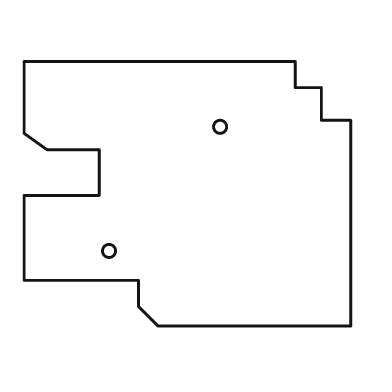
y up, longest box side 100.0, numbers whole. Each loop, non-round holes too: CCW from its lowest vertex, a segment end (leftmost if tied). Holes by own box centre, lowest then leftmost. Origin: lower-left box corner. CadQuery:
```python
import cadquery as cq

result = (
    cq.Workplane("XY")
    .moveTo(41.0, 0.0)
    .lineTo(100.0, 0.0)
    .lineTo(100.0, 63.0)
    .lineTo(91.0, 63.0)
    .lineTo(91.0, 73.0)
    .lineTo(83.0, 73.0)
    .lineTo(83.0, 81.0)
    .lineTo(0.0, 81.0)
    .lineTo(0.0, 59.0)
    .lineTo(7.0, 54.0)
    .lineTo(23.0, 54.0)
    .lineTo(23.0, 40.0)
    .lineTo(0.0, 40.0)
    .lineTo(0.0, 14.0)
    .lineTo(35.0, 14.0)
    .lineTo(35.0, 6.0)
    .close()
    .moveTo(26.0, 23.0)
    .circle(2.0)
    .moveTo(60.0, 61.0)
    .circle(2.0)
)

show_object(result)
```